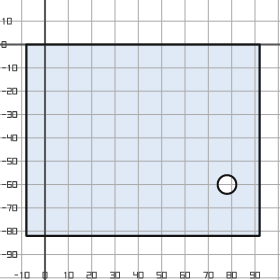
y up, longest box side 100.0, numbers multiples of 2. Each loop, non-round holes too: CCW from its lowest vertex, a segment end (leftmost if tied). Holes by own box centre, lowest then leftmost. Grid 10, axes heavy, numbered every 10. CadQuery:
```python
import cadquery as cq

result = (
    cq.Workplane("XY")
    .moveTo(-8.0, -82.0)
    .lineTo(92.0, -82.0)
    .lineTo(92.0, 0.0)
    .lineTo(-8.0, 0.0)
    .close()
    .moveTo(78.0, -60.0)
    .circle(4.0)
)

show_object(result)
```